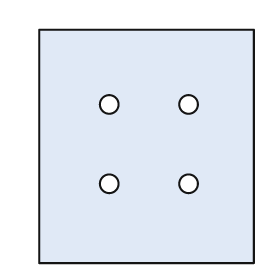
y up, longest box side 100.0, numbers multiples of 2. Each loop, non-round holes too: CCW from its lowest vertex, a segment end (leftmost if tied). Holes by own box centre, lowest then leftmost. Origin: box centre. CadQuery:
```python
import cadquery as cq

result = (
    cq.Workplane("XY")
    .moveTo(-46.0, -50.0)
    .lineTo(46.0, -50.0)
    .lineTo(46.0, 50.0)
    .lineTo(-46.0, 50.0)
    .close()
    .moveTo(-16.0, -16.0)
    .circle(4.0)
    .moveTo(18.0, -16.0)
    .circle(4.0)
    .moveTo(-16.0, 18.0)
    .circle(4.0)
    .moveTo(18.0, 18.0)
    .circle(4.0)
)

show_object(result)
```